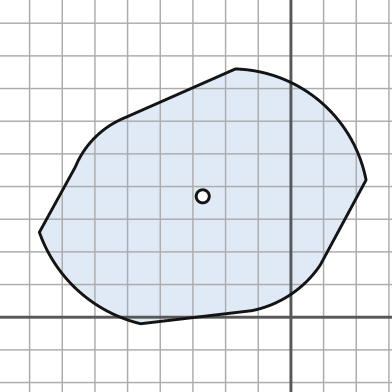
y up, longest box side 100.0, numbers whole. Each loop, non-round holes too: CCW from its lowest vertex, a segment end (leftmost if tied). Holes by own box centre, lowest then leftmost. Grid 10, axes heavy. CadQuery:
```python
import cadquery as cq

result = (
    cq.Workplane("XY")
    .moveTo(-46.0, -2.0)
    .lineTo(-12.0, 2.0)
    .threePointArc((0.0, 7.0), (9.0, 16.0))
    .lineTo(23.0, 42.0)
    .threePointArc((9.0, 66.0), (-17.0, 76.0))
    .lineTo(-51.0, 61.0)
    .threePointArc((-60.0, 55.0), (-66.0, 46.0))
    .lineTo(-77.0, 26.0)
    .threePointArc((-65.0, 8.0), (-46.0, -2.0))
    .close()
    .moveTo(-27.0, 37.0)
    .circle(2.0)
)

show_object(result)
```